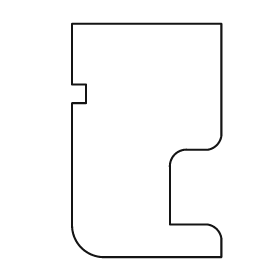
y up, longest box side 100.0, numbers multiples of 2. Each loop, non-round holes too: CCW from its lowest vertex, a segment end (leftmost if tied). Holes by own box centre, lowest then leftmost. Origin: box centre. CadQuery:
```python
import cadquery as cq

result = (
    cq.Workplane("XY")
    .moveTo(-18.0, -50.0)
    .lineTo(32.0, -50.0)
    .lineTo(32.0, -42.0)
    .threePointArc((30.0, -38.0), (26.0, -36.0))
    .lineTo(10.0, -36.0)
    .lineTo(10.0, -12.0)
    .threePointArc((12.0, -6.0), (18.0, -4.0))
    .lineTo(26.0, -4.0)
    .threePointArc((30.0, -2.0), (32.0, 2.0))
    .lineTo(32.0, 50.0)
    .lineTo(-32.0, 50.0)
    .lineTo(-32.0, 24.0)
    .lineTo(-26.0, 24.0)
    .lineTo(-26.0, 16.0)
    .lineTo(-32.0, 16.0)
    .lineTo(-32.0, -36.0)
    .threePointArc((-28.0, -46.0), (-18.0, -50.0))
    .close()
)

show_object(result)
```